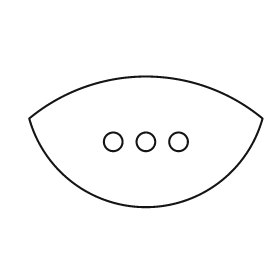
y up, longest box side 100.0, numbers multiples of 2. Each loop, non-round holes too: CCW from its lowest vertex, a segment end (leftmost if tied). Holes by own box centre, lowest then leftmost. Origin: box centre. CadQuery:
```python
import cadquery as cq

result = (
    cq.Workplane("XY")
    .moveTo(-50.0, 10.0)
    .threePointArc((0.0, -28.0), (50.0, 10.0))
    .threePointArc((0.0, 28.0), (-50.0, 10.0))
    .close()
    .moveTo(-14.0, 0.0)
    .circle(4.0)
    .moveTo(0.0, 0.0)
    .circle(4.0)
    .moveTo(14.0, 0.0)
    .circle(4.0)
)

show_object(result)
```